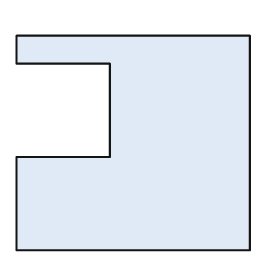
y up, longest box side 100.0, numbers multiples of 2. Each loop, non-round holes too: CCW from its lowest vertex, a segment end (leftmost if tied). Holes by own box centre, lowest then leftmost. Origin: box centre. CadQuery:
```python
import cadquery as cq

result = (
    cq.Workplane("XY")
    .moveTo(-50.0, -46.0)
    .lineTo(50.0, -46.0)
    .lineTo(50.0, 46.0)
    .lineTo(-50.0, 46.0)
    .lineTo(-50.0, 34.0)
    .lineTo(-10.0, 34.0)
    .lineTo(-10.0, -6.0)
    .lineTo(-50.0, -6.0)
    .close()
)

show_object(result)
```